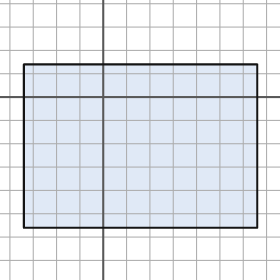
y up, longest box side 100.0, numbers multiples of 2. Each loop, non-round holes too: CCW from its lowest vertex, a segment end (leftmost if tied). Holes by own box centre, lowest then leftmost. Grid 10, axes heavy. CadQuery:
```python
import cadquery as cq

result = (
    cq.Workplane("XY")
    .moveTo(-34.0, -56.0)
    .lineTo(66.0, -56.0)
    .lineTo(66.0, 14.0)
    .lineTo(-34.0, 14.0)
    .close()
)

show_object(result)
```